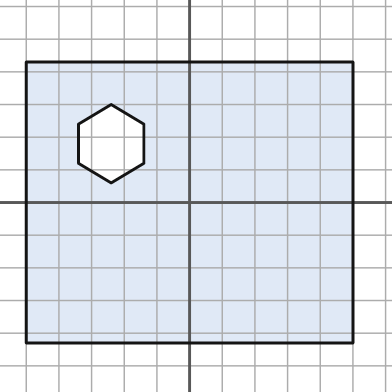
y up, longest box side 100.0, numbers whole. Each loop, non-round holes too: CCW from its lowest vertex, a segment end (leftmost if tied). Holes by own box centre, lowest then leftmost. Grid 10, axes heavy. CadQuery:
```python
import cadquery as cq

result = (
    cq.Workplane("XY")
    .moveTo(-50.0, -43.0)
    .lineTo(50.0, -43.0)
    .lineTo(50.0, 43.0)
    .lineTo(-50.0, 43.0)
    .close()
    .moveTo(-24.0, 6.0)
    .lineTo(-14.0, 12.0)
    .lineTo(-14.0, 24.0)
    .lineTo(-24.0, 30.0)
    .lineTo(-34.0, 24.0)
    .lineTo(-34.0, 12.0)
    .close()
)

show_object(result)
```